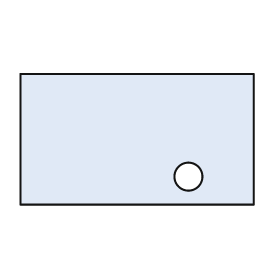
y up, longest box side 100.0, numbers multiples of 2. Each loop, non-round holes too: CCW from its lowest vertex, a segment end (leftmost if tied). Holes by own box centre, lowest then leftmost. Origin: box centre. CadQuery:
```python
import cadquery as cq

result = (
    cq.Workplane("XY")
    .moveTo(-50.0, -28.0)
    .lineTo(50.0, -28.0)
    .lineTo(50.0, 28.0)
    .lineTo(-50.0, 28.0)
    .close()
    .moveTo(22.0, -16.0)
    .circle(6.0)
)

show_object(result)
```